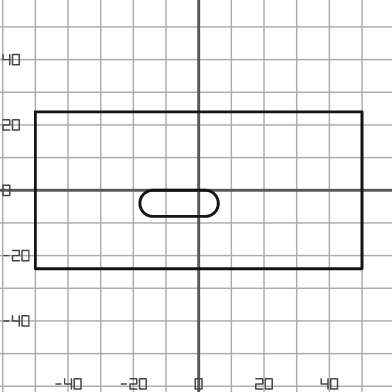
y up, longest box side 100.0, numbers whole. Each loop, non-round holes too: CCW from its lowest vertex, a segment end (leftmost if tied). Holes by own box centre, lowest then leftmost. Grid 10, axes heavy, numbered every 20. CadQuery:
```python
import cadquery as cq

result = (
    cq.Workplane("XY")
    .moveTo(-50.0, -24.0)
    .lineTo(50.0, -24.0)
    .lineTo(50.0, 24.0)
    .lineTo(-50.0, 24.0)
    .close()
    .moveTo(-14.0, -8.0)
    .lineTo(2.0, -8.0)
    .threePointArc((6.0, -4.0), (2.0, 0.0))
    .lineTo(-14.0, 0.0)
    .threePointArc((-18.0, -4.0), (-14.0, -8.0))
    .close()
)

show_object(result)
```